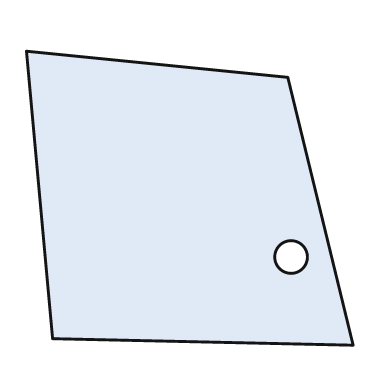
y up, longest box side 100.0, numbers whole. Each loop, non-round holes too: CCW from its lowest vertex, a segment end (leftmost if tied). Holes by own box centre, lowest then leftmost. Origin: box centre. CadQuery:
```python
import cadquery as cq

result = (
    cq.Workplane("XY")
    .moveTo(50.0, -45.0)
    .lineTo(30.0, 37.0)
    .lineTo(-50.0, 45.0)
    .lineTo(-42.0, -43.0)
    .close()
    .moveTo(31.0, -18.0)
    .circle(5.0)
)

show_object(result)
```